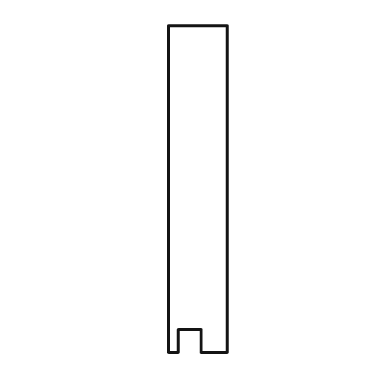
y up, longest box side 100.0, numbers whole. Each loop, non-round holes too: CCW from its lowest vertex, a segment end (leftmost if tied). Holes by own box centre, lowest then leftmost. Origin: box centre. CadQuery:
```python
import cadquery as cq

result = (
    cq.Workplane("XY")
    .moveTo(-9.0, -50.0)
    .lineTo(-6.0, -50.0)
    .lineTo(-6.0, -43.0)
    .lineTo(1.0, -43.0)
    .lineTo(1.0, -50.0)
    .lineTo(9.0, -50.0)
    .lineTo(9.0, 50.0)
    .lineTo(-9.0, 50.0)
    .close()
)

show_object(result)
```